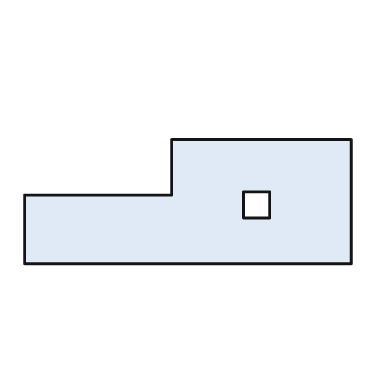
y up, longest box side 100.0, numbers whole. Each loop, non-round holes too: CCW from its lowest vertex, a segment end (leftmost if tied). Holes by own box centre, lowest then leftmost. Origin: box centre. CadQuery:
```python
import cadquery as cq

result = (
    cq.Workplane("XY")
    .moveTo(-50.0, -19.0)
    .lineTo(50.0, -19.0)
    .lineTo(50.0, 19.0)
    .lineTo(-5.0, 19.0)
    .lineTo(-5.0, 2.0)
    .lineTo(-50.0, 2.0)
    .close()
    .moveTo(17.0, -5.0)
    .lineTo(25.0, -5.0)
    .lineTo(25.0, 3.0)
    .lineTo(17.0, 3.0)
    .close()
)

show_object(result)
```